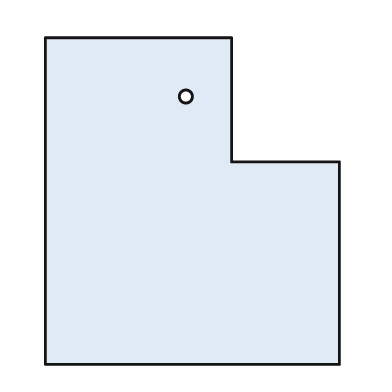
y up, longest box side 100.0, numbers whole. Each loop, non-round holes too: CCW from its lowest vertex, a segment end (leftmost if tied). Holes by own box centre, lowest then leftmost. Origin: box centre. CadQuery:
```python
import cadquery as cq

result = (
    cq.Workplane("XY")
    .moveTo(-45.0, -50.0)
    .lineTo(45.0, -50.0)
    .lineTo(45.0, 12.0)
    .lineTo(12.0, 12.0)
    .lineTo(12.0, 50.0)
    .lineTo(-45.0, 50.0)
    .close()
    .moveTo(-2.0, 32.0)
    .circle(2.0)
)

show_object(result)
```